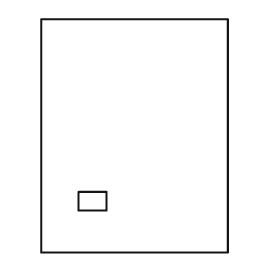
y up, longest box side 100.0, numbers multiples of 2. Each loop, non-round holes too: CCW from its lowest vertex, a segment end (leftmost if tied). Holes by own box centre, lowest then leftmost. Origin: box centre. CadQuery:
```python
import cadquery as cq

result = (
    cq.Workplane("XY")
    .moveTo(-40.0, -50.0)
    .lineTo(40.0, -50.0)
    .lineTo(40.0, 50.0)
    .lineTo(-40.0, 50.0)
    .close()
    .moveTo(-24.0, -32.0)
    .lineTo(-12.0, -32.0)
    .lineTo(-12.0, -24.0)
    .lineTo(-24.0, -24.0)
    .close()
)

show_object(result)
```